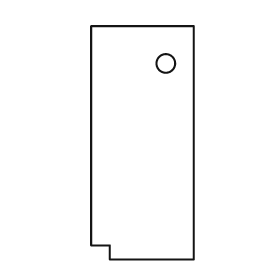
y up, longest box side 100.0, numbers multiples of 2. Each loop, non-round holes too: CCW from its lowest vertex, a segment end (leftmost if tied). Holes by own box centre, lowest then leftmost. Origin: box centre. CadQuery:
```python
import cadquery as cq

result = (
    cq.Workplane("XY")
    .moveTo(-14.0, -50.0)
    .lineTo(22.0, -50.0)
    .lineTo(22.0, 50.0)
    .lineTo(-22.0, 50.0)
    .lineTo(-22.0, -44.0)
    .lineTo(-14.0, -44.0)
    .close()
    .moveTo(10.0, 34.0)
    .circle(4.0)
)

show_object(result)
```